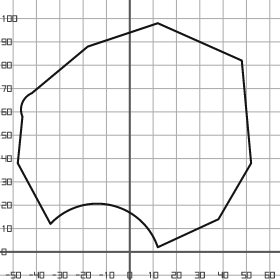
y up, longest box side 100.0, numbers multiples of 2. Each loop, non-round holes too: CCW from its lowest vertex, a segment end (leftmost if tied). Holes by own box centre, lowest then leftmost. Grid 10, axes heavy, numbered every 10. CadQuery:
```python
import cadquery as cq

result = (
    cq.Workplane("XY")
    .moveTo(12.0, 2.0)
    .lineTo(38.0, 14.0)
    .lineTo(52.0, 38.0)
    .lineTo(48.0, 82.0)
    .lineTo(12.0, 98.0)
    .lineTo(-18.0, 88.0)
    .lineTo(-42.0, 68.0)
    .threePointArc((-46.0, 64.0), (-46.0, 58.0))
    .lineTo(-48.0, 38.0)
    .lineTo(-34.0, 12.0)
    .threePointArc((-8.0, 20.0), (12.0, 2.0))
    .close()
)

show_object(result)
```